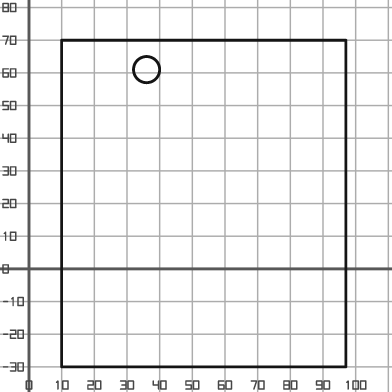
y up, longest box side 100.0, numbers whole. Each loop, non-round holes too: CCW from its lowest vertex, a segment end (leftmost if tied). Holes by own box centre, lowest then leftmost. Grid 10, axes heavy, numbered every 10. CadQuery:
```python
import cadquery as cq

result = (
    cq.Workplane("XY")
    .moveTo(10.0, -30.0)
    .lineTo(97.0, -30.0)
    .lineTo(97.0, 70.0)
    .lineTo(10.0, 70.0)
    .close()
    .moveTo(36.0, 61.0)
    .circle(4.0)
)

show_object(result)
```